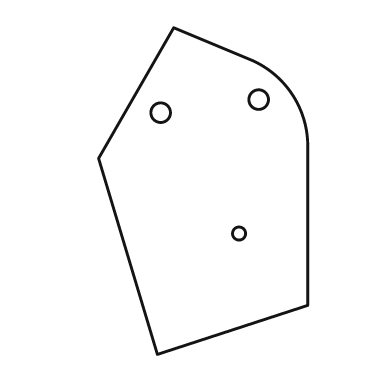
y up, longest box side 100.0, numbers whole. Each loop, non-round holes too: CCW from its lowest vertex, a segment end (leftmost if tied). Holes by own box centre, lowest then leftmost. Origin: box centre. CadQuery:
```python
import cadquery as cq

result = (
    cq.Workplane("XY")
    .moveTo(-14.0, -50.0)
    .lineTo(32.0, -35.0)
    .lineTo(32.0, 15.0)
    .threePointArc((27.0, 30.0), (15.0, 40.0))
    .lineTo(-9.0, 50.0)
    .lineTo(-32.0, 10.0)
    .close()
    .moveTo(11.0, -13.0)
    .circle(2.0)
    .moveTo(-13.0, 24.0)
    .circle(3.0)
    .moveTo(17.0, 28.0)
    .circle(3.0)
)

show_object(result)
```